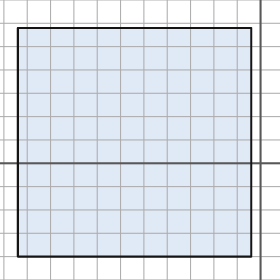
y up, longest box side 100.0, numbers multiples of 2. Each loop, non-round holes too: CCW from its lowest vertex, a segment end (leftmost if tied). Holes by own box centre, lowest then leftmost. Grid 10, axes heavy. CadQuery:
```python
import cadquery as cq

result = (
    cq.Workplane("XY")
    .moveTo(-104.0, -40.0)
    .lineTo(-4.0, -40.0)
    .lineTo(-4.0, 58.0)
    .lineTo(-104.0, 58.0)
    .close()
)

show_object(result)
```